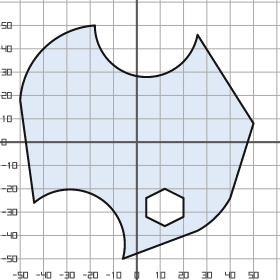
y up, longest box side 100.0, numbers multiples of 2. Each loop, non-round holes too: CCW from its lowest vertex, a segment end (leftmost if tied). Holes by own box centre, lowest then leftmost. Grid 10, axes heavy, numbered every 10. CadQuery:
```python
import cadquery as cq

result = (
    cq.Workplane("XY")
    .moveTo(-6.0, -50.0)
    .lineTo(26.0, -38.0)
    .threePointArc((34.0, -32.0), (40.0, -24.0))
    .lineTo(50.0, 8.0)
    .lineTo(26.0, 46.0)
    .threePointArc((2.0, 28.0), (-18.0, 50.0))
    .threePointArc((-40.0, 40.0), (-50.0, 18.0))
    .lineTo(-44.0, -26.0)
    .threePointArc((-16.0, -24.0), (-6.0, -50.0))
    .close()
    .moveTo(12.0, -36.0)
    .lineTo(20.0, -32.0)
    .lineTo(20.0, -24.0)
    .lineTo(12.0, -20.0)
    .lineTo(4.0, -24.0)
    .lineTo(4.0, -32.0)
    .close()
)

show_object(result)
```